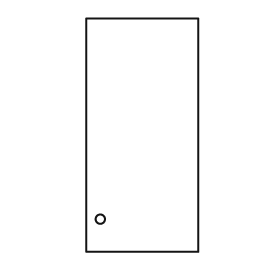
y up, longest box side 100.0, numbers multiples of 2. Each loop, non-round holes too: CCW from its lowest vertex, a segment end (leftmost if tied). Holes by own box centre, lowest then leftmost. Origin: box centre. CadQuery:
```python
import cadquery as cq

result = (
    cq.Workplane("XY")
    .moveTo(-24.0, -50.0)
    .lineTo(24.0, -50.0)
    .lineTo(24.0, 50.0)
    .lineTo(-24.0, 50.0)
    .close()
    .moveTo(-18.0, -36.0)
    .circle(2.0)
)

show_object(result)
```